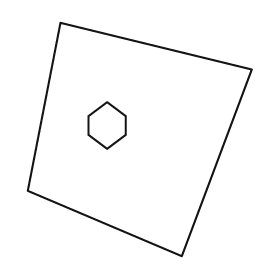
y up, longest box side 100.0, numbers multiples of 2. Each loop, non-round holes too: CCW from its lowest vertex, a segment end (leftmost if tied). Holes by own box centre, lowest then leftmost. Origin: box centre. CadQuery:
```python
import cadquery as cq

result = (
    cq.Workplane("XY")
    .moveTo(18.0, -50.0)
    .lineTo(48.0, 30.0)
    .lineTo(-34.0, 50.0)
    .lineTo(-48.0, -22.0)
    .close()
    .moveTo(-14.0, -4.0)
    .lineTo(-6.0, 2.0)
    .lineTo(-6.0, 10.0)
    .lineTo(-14.0, 16.0)
    .lineTo(-22.0, 10.0)
    .lineTo(-22.0, 2.0)
    .close()
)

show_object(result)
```